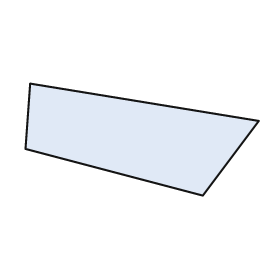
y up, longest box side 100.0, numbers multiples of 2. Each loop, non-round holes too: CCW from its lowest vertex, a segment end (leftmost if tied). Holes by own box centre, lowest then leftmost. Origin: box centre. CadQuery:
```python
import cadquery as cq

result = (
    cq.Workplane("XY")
    .moveTo(26.0, -24.0)
    .lineTo(50.0, 8.0)
    .lineTo(-48.0, 24.0)
    .lineTo(-50.0, -4.0)
    .close()
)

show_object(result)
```